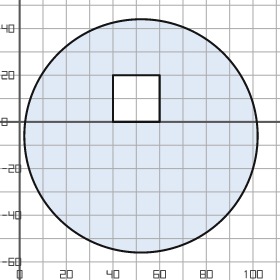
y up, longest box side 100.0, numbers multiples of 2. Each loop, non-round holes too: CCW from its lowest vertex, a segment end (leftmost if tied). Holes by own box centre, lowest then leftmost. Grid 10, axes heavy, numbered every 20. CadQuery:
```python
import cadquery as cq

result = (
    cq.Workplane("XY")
    .moveTo(52.0, -6.0)
    .circle(50.0)
    .moveTo(40.0, 0.0)
    .lineTo(60.0, 0.0)
    .lineTo(60.0, 20.0)
    .lineTo(40.0, 20.0)
    .close()
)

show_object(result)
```